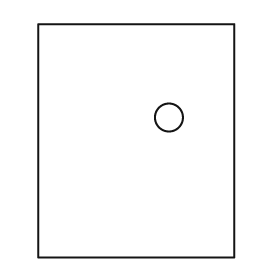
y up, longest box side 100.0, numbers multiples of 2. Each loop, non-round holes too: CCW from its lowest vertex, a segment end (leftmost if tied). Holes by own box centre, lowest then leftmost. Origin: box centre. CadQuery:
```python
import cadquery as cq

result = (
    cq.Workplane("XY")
    .moveTo(-42.0, -50.0)
    .lineTo(42.0, -50.0)
    .lineTo(42.0, 50.0)
    .lineTo(-42.0, 50.0)
    .close()
    .moveTo(14.0, 10.0)
    .circle(6.0)
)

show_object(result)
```